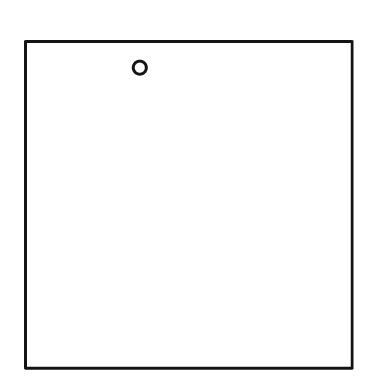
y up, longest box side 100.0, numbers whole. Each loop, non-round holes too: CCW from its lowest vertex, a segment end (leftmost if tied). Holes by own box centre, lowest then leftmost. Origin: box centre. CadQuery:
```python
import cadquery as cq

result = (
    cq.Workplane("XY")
    .moveTo(-50.0, -50.0)
    .lineTo(50.0, -50.0)
    .lineTo(50.0, 50.0)
    .lineTo(-50.0, 50.0)
    .close()
    .moveTo(-15.0, 42.0)
    .circle(2.0)
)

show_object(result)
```